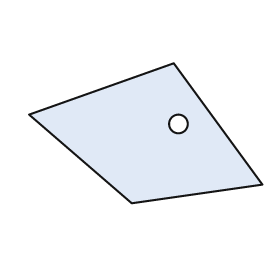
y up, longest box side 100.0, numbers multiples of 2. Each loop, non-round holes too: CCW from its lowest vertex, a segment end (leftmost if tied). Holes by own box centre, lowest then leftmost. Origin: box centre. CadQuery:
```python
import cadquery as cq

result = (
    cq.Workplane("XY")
    .moveTo(-6.0, -30.0)
    .lineTo(50.0, -22.0)
    .lineTo(12.0, 30.0)
    .lineTo(-50.0, 8.0)
    .close()
    .moveTo(14.0, 4.0)
    .circle(4.0)
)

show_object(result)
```